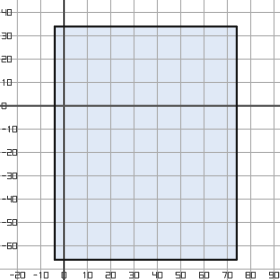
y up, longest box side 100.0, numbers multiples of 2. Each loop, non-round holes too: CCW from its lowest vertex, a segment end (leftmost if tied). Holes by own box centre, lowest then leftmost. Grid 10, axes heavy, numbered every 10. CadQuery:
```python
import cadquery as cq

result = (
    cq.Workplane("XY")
    .moveTo(-4.0, -66.0)
    .lineTo(74.0, -66.0)
    .lineTo(74.0, 34.0)
    .lineTo(-4.0, 34.0)
    .close()
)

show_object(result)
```